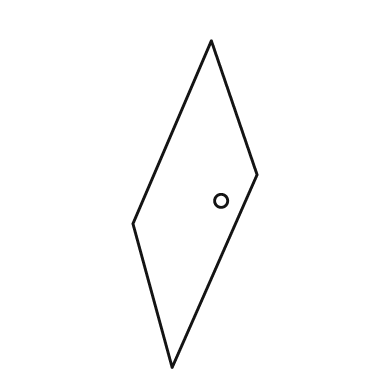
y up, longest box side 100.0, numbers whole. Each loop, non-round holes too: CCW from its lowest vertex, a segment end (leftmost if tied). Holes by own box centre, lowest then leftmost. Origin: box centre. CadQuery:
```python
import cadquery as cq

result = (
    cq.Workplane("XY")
    .moveTo(-7.0, -50.0)
    .lineTo(19.0, 9.0)
    .lineTo(5.0, 50.0)
    .lineTo(-19.0, -6.0)
    .close()
    .moveTo(8.0, 1.0)
    .circle(2.0)
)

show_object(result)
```